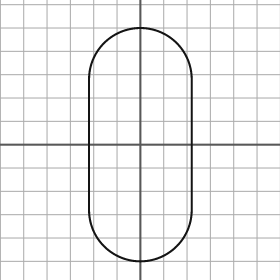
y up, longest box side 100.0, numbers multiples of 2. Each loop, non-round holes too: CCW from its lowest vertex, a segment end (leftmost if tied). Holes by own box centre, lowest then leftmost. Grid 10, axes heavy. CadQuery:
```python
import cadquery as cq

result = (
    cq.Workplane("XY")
    .moveTo(-22.0, -28.0)
    .threePointArc((0.0, -50.0), (22.0, -28.0))
    .lineTo(22.0, 28.0)
    .threePointArc((0.0, 50.0), (-22.0, 28.0))
    .close()
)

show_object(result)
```